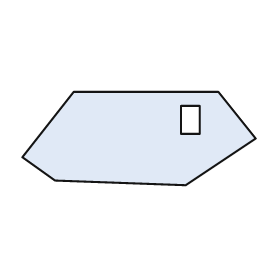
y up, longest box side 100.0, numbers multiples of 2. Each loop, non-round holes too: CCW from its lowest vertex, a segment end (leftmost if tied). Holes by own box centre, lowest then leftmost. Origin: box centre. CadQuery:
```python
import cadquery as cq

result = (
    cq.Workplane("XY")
    .moveTo(20.0, -20.0)
    .lineTo(50.0, 0.0)
    .lineTo(34.0, 20.0)
    .lineTo(-28.0, 20.0)
    .lineTo(-50.0, -8.0)
    .lineTo(-36.0, -18.0)
    .close()
    .moveTo(18.0, 2.0)
    .lineTo(26.0, 2.0)
    .lineTo(26.0, 14.0)
    .lineTo(18.0, 14.0)
    .close()
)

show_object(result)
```